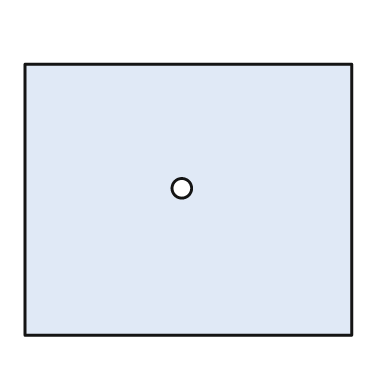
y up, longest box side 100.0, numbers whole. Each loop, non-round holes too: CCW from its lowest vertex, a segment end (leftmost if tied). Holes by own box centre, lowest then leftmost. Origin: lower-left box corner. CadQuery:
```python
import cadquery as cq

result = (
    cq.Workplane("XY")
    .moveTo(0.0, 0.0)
    .lineTo(100.0, 0.0)
    .lineTo(100.0, 83.0)
    .lineTo(0.0, 83.0)
    .close()
    .moveTo(48.0, 45.0)
    .circle(3.0)
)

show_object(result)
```